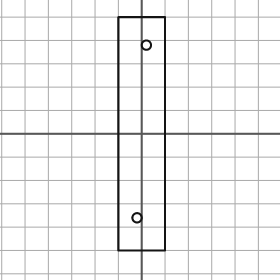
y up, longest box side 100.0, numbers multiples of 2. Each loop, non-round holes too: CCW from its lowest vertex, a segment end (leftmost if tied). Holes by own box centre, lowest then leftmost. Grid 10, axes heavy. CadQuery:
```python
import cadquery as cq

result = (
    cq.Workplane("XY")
    .moveTo(-10.0, -50.0)
    .lineTo(10.0, -50.0)
    .lineTo(10.0, 50.0)
    .lineTo(-10.0, 50.0)
    .close()
    .moveTo(-2.0, -36.0)
    .circle(2.0)
    .moveTo(2.0, 38.0)
    .circle(2.0)
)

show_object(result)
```